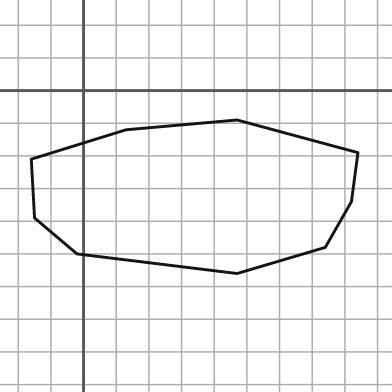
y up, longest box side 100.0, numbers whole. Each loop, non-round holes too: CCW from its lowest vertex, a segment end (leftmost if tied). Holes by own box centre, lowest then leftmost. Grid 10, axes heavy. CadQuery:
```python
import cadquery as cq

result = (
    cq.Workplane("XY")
    .moveTo(47.0, -56.0)
    .lineTo(74.0, -48.0)
    .lineTo(82.0, -34.0)
    .lineTo(84.0, -19.0)
    .lineTo(47.0, -9.0)
    .lineTo(13.0, -12.0)
    .lineTo(-16.0, -21.0)
    .lineTo(-15.0, -39.0)
    .lineTo(-2.0, -50.0)
    .close()
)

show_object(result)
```